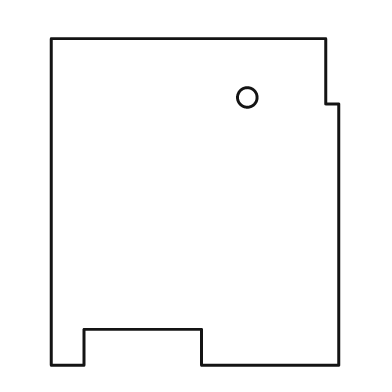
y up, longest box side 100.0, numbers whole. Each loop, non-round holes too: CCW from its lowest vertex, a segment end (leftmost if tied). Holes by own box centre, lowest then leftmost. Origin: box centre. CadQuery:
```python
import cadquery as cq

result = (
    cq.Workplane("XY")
    .moveTo(-44.0, -50.0)
    .lineTo(-34.0, -50.0)
    .lineTo(-34.0, -39.0)
    .lineTo(2.0, -39.0)
    .lineTo(2.0, -50.0)
    .lineTo(44.0, -50.0)
    .lineTo(44.0, 30.0)
    .lineTo(40.0, 30.0)
    .lineTo(40.0, 50.0)
    .lineTo(-44.0, 50.0)
    .close()
    .moveTo(16.0, 32.0)
    .circle(3.0)
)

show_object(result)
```